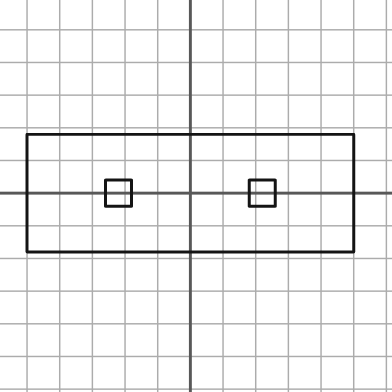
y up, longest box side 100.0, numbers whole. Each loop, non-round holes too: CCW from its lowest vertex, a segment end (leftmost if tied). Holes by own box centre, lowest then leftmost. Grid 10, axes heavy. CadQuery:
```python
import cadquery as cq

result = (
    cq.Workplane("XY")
    .moveTo(-50.0, -18.0)
    .lineTo(50.0, -18.0)
    .lineTo(50.0, 18.0)
    .lineTo(-50.0, 18.0)
    .close()
    .moveTo(-26.0, -4.0)
    .lineTo(-18.0, -4.0)
    .lineTo(-18.0, 4.0)
    .lineTo(-26.0, 4.0)
    .close()
    .moveTo(18.0, -4.0)
    .lineTo(26.0, -4.0)
    .lineTo(26.0, 4.0)
    .lineTo(18.0, 4.0)
    .close()
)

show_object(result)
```